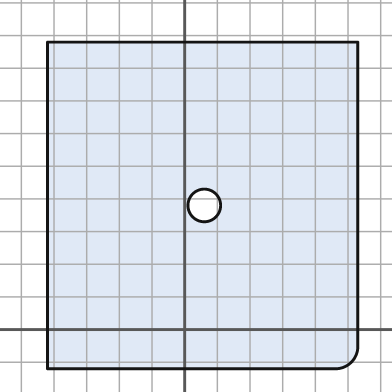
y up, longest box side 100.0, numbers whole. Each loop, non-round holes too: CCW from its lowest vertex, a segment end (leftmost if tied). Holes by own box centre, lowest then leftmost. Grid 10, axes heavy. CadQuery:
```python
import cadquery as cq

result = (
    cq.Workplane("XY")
    .moveTo(-42.0, -12.0)
    .lineTo(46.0, -12.0)
    .threePointArc((51.0, -10.0), (53.0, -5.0))
    .lineTo(53.0, 88.0)
    .lineTo(-42.0, 88.0)
    .close()
    .moveTo(6.0, 38.0)
    .circle(5.0)
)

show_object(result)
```